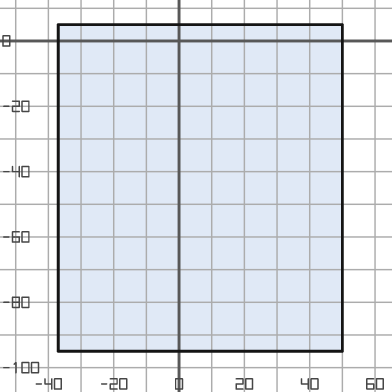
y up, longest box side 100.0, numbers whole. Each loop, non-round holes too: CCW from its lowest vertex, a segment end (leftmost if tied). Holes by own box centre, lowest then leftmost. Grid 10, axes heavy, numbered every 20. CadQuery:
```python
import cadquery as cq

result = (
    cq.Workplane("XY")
    .moveTo(-37.0, -95.0)
    .lineTo(50.0, -95.0)
    .lineTo(50.0, 5.0)
    .lineTo(-37.0, 5.0)
    .close()
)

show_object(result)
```